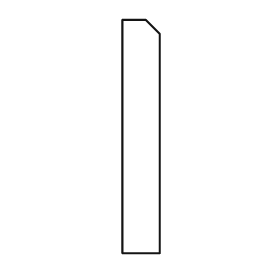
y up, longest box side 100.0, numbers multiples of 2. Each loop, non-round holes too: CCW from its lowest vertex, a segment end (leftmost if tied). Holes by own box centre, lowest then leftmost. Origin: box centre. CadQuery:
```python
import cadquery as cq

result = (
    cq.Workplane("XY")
    .moveTo(-8.0, -50.0)
    .lineTo(8.0, -50.0)
    .lineTo(8.0, 44.0)
    .lineTo(2.0, 50.0)
    .lineTo(-8.0, 50.0)
    .close()
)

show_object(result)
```